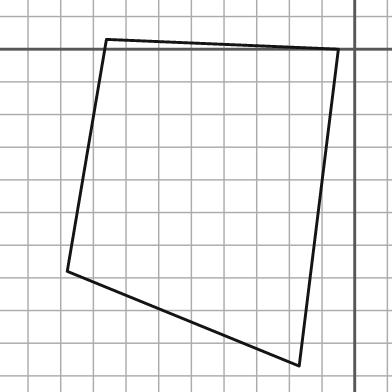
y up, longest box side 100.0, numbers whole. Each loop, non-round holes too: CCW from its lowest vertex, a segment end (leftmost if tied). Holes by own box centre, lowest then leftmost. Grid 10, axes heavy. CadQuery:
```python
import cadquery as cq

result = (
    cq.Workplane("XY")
    .moveTo(-17.0, -97.0)
    .lineTo(-5.0, 0.0)
    .lineTo(-76.0, 3.0)
    .lineTo(-88.0, -68.0)
    .close()
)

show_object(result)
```